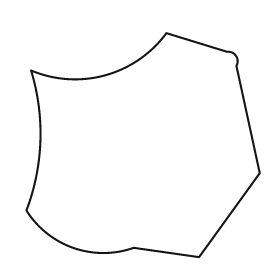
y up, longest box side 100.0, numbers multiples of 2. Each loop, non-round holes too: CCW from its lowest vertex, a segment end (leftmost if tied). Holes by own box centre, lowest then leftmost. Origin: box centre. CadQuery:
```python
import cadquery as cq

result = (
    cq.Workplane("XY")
    .moveTo(24.0, -48.0)
    .lineTo(50.0, -12.0)
    .lineTo(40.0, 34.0)
    .threePointArc((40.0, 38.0), (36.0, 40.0))
    .lineTo(10.0, 48.0)
    .threePointArc((-16.0, 30.0), (-48.0, 32.0))
    .threePointArc((-44.0, 2.0), (-50.0, -28.0))
    .threePointArc((-30.0, -44.0), (-4.0, -44.0))
    .close()
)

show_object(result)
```